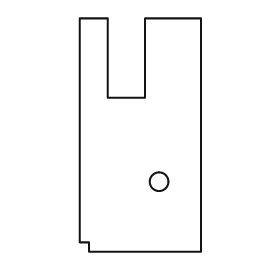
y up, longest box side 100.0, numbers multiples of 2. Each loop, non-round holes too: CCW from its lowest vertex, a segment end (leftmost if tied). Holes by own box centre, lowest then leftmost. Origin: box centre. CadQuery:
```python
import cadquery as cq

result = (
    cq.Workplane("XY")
    .moveTo(-22.0, -50.0)
    .lineTo(26.0, -50.0)
    .lineTo(26.0, 50.0)
    .lineTo(2.0, 50.0)
    .lineTo(2.0, 16.0)
    .lineTo(-14.0, 16.0)
    .lineTo(-14.0, 50.0)
    .lineTo(-26.0, 50.0)
    .lineTo(-26.0, -46.0)
    .lineTo(-22.0, -46.0)
    .close()
    .moveTo(8.0, -20.0)
    .circle(4.0)
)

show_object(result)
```